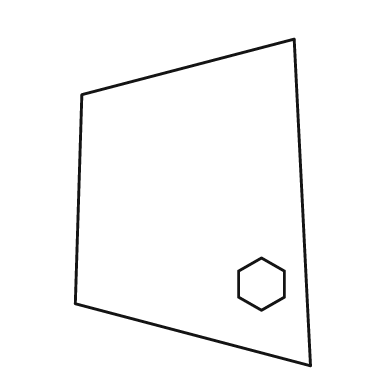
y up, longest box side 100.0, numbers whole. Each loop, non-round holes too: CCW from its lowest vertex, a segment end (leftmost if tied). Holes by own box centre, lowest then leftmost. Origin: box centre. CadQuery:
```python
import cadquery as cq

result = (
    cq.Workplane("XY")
    .moveTo(36.0, -50.0)
    .lineTo(31.0, 50.0)
    .lineTo(-34.0, 33.0)
    .lineTo(-36.0, -31.0)
    .close()
    .moveTo(21.0, -33.0)
    .lineTo(28.0, -29.0)
    .lineTo(28.0, -21.0)
    .lineTo(21.0, -17.0)
    .lineTo(14.0, -21.0)
    .lineTo(14.0, -29.0)
    .close()
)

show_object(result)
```